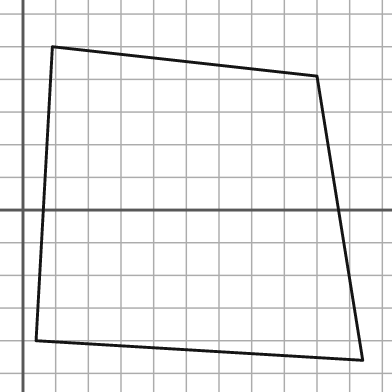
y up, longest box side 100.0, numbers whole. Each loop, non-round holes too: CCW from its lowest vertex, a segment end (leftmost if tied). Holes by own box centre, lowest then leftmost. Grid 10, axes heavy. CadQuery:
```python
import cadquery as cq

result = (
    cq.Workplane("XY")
    .moveTo(104.0, -46.0)
    .lineTo(90.0, 41.0)
    .lineTo(9.0, 50.0)
    .lineTo(4.0, -40.0)
    .close()
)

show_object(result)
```